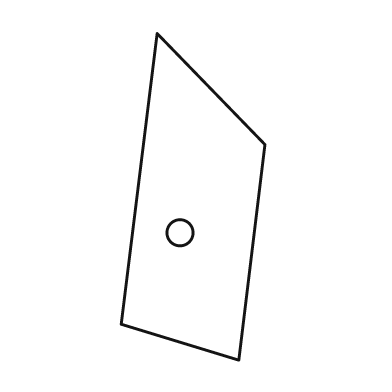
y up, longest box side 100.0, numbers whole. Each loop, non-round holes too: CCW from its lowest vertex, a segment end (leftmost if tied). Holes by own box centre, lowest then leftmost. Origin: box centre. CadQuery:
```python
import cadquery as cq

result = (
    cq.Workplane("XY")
    .moveTo(14.0, -50.0)
    .lineTo(22.0, 16.0)
    .lineTo(-11.0, 50.0)
    .lineTo(-22.0, -39.0)
    .close()
    .moveTo(-4.0, -11.0)
    .circle(4.0)
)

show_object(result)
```